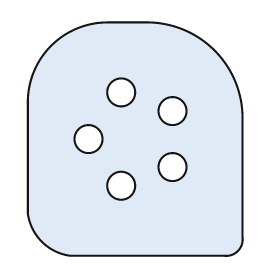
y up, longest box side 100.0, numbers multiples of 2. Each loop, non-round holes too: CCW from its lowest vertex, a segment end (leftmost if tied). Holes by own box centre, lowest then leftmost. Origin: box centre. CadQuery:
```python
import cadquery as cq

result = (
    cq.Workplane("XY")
    .moveTo(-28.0, -50.0)
    .lineTo(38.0, -50.0)
    .threePointArc((44.0, -48.0), (46.0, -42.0))
    .lineTo(46.0, 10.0)
    .threePointArc((34.0, 38.0), (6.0, 50.0))
    .lineTo(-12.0, 50.0)
    .threePointArc((-36.0, 40.0), (-46.0, 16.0))
    .lineTo(-46.0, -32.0)
    .threePointArc((-40.0, -44.0), (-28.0, -50.0))
    .close()
    .moveTo(-6.0, -20.0)
    .circle(6.0)
    .moveTo(16.0, -12.0)
    .circle(6.0)
    .moveTo(-20.0, 0.0)
    .circle(6.0)
    .moveTo(16.0, 12.0)
    .circle(6.0)
    .moveTo(-6.0, 20.0)
    .circle(6.0)
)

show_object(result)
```